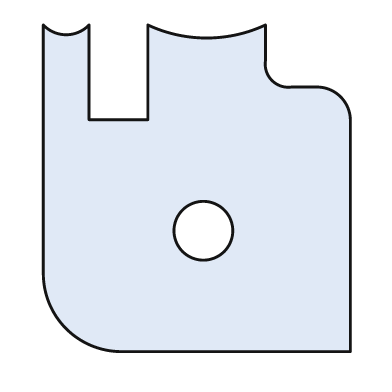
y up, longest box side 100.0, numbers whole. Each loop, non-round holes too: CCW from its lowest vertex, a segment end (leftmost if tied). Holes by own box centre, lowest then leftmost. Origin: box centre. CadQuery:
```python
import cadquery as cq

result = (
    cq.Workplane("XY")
    .moveTo(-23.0, -50.0)
    .lineTo(47.0, -50.0)
    .lineTo(47.0, 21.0)
    .threePointArc((44.0, 28.0), (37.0, 31.0))
    .lineTo(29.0, 31.0)
    .threePointArc((23.0, 33.0), (21.0, 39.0))
    .lineTo(21.0, 50.0)
    .threePointArc((3.0, 46.0), (-15.0, 50.0))
    .lineTo(-15.0, 21.0)
    .lineTo(-33.0, 21.0)
    .lineTo(-33.0, 50.0)
    .threePointArc((-40.0, 47.0), (-47.0, 50.0))
    .lineTo(-47.0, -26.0)
    .threePointArc((-40.0, -43.0), (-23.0, -50.0))
    .close()
    .moveTo(2.0, -13.0)
    .circle(9.0)
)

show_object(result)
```